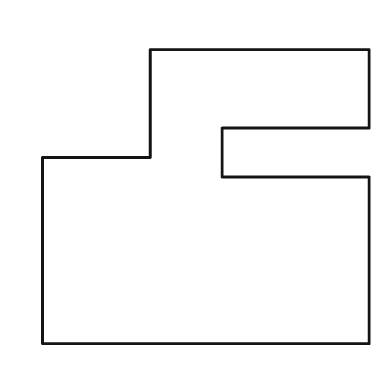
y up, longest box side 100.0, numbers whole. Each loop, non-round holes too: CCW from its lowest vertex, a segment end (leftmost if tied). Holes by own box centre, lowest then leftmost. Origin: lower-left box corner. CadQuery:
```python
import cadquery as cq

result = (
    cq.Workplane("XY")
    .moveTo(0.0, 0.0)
    .lineTo(100.0, 0.0)
    .lineTo(100.0, 51.0)
    .lineTo(55.0, 51.0)
    .lineTo(55.0, 66.0)
    .lineTo(100.0, 66.0)
    .lineTo(100.0, 90.0)
    .lineTo(33.0, 90.0)
    .lineTo(33.0, 57.0)
    .lineTo(0.0, 57.0)
    .close()
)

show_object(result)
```